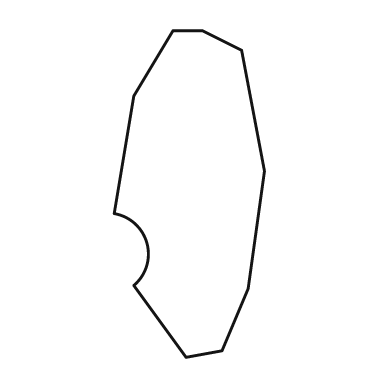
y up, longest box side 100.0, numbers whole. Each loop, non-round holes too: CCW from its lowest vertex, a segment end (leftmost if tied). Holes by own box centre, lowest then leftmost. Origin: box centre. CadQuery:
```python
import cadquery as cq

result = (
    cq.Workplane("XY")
    .moveTo(-1.0, -50.0)
    .lineTo(10.0, -48.0)
    .lineTo(18.0, -29.0)
    .lineTo(23.0, 7.0)
    .lineTo(16.0, 44.0)
    .lineTo(4.0, 50.0)
    .lineTo(-5.0, 50.0)
    .lineTo(-17.0, 30.0)
    .lineTo(-23.0, -6.0)
    .threePointArc((-13.0, -15.0), (-17.0, -28.0))
    .close()
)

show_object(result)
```